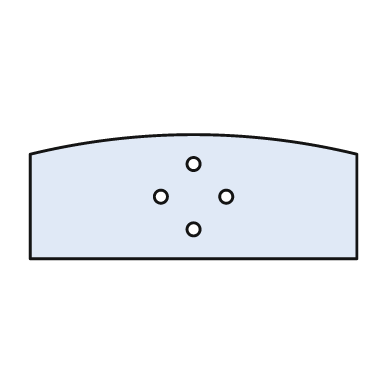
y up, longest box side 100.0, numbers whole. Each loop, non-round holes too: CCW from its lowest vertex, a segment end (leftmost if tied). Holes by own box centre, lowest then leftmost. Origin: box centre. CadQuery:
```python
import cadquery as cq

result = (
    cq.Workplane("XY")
    .moveTo(-50.0, -19.0)
    .lineTo(50.0, -19.0)
    .lineTo(50.0, 13.0)
    .threePointArc((0.0, 19.0), (-50.0, 13.0))
    .close()
    .moveTo(0.0, -10.0)
    .circle(2.0)
    .moveTo(-10.0, 0.0)
    .circle(2.0)
    .moveTo(10.0, 0.0)
    .circle(2.0)
    .moveTo(0.0, 10.0)
    .circle(2.0)
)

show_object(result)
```